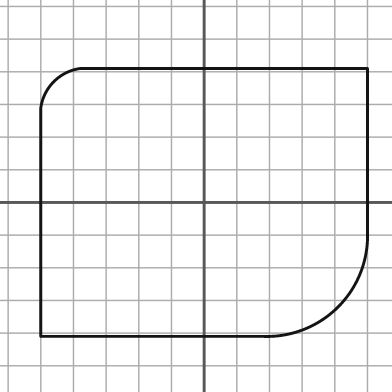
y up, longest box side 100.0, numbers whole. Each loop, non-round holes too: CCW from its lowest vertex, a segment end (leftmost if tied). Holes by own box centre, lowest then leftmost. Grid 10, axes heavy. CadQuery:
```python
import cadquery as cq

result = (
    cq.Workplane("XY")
    .moveTo(-50.0, -41.0)
    .lineTo(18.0, -41.0)
    .threePointArc((41.0, -32.0), (50.0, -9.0))
    .lineTo(50.0, 41.0)
    .lineTo(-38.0, 41.0)
    .threePointArc((-46.0, 37.0), (-50.0, 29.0))
    .close()
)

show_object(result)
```